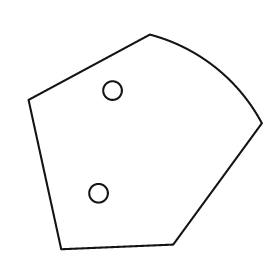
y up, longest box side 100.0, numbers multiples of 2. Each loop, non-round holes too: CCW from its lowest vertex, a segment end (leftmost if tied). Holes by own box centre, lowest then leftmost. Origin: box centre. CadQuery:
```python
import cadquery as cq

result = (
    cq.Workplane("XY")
    .moveTo(-36.0, -46.0)
    .lineTo(12.0, -44.0)
    .lineTo(50.0, 8.0)
    .threePointArc((30.0, 32.0), (2.0, 46.0))
    .lineTo(-50.0, 18.0)
    .close()
    .moveTo(-20.0, -22.0)
    .circle(4.0)
    .moveTo(-14.0, 22.0)
    .circle(4.0)
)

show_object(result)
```